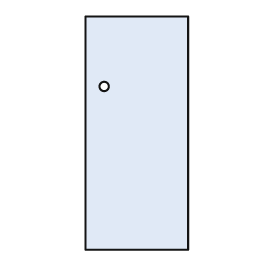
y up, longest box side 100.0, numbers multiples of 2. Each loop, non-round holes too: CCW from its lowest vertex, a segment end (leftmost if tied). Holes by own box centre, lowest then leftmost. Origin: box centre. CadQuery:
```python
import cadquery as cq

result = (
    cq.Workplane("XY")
    .moveTo(-22.0, -50.0)
    .lineTo(22.0, -50.0)
    .lineTo(22.0, 50.0)
    .lineTo(-22.0, 50.0)
    .close()
    .moveTo(-14.0, 20.0)
    .circle(2.0)
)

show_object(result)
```